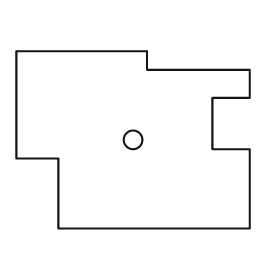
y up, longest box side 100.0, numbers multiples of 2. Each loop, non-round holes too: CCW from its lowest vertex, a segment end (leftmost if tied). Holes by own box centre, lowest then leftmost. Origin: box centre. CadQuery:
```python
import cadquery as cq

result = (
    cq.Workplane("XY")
    .moveTo(-32.0, -38.0)
    .lineTo(50.0, -38.0)
    .lineTo(50.0, -4.0)
    .lineTo(34.0, -4.0)
    .lineTo(34.0, 18.0)
    .lineTo(50.0, 18.0)
    .lineTo(50.0, 30.0)
    .lineTo(6.0, 30.0)
    .lineTo(6.0, 38.0)
    .lineTo(-50.0, 38.0)
    .lineTo(-50.0, -8.0)
    .lineTo(-32.0, -8.0)
    .close()
    .moveTo(0.0, 0.0)
    .circle(4.0)
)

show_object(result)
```